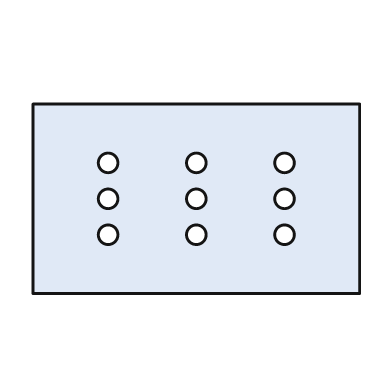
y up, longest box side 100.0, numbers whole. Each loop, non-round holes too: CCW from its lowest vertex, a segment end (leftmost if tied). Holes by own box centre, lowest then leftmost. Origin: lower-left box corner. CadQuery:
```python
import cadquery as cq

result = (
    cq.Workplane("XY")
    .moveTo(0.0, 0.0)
    .lineTo(100.0, 0.0)
    .lineTo(100.0, 58.0)
    .lineTo(0.0, 58.0)
    .close()
    .moveTo(23.0, 18.0)
    .circle(3.0)
    .moveTo(50.0, 18.0)
    .circle(3.0)
    .moveTo(77.0, 18.0)
    .circle(3.0)
    .moveTo(23.0, 29.0)
    .circle(3.0)
    .moveTo(50.0, 29.0)
    .circle(3.0)
    .moveTo(77.0, 29.0)
    .circle(3.0)
    .moveTo(23.0, 40.0)
    .circle(3.0)
    .moveTo(50.0, 40.0)
    .circle(3.0)
    .moveTo(77.0, 40.0)
    .circle(3.0)
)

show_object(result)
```